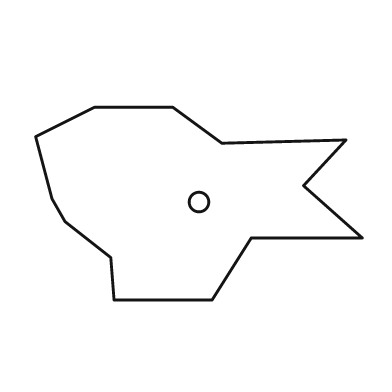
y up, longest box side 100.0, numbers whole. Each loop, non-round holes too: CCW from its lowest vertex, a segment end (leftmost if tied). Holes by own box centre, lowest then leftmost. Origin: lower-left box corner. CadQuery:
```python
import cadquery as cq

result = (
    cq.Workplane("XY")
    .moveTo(24.0, 0.0)
    .lineTo(54.0, 0.0)
    .lineTo(66.0, 19.0)
    .lineTo(100.0, 19.0)
    .lineTo(82.0, 35.0)
    .lineTo(95.0, 49.0)
    .lineTo(57.0, 48.0)
    .lineTo(42.0, 59.0)
    .lineTo(18.0, 59.0)
    .lineTo(0.0, 50.0)
    .lineTo(5.0, 31.0)
    .lineTo(9.0, 24.0)
    .lineTo(23.0, 13.0)
    .close()
    .moveTo(50.0, 30.0)
    .circle(3.0)
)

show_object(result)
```